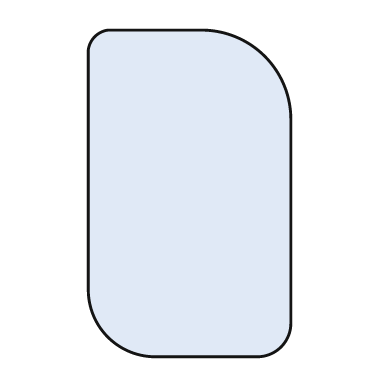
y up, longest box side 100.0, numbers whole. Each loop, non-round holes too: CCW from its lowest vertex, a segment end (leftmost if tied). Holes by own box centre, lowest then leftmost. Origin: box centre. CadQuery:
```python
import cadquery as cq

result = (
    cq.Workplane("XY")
    .moveTo(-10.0, -50.0)
    .lineTo(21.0, -50.0)
    .threePointArc((28.0, -47.0), (31.0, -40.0))
    .lineTo(31.0, 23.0)
    .threePointArc((23.0, 42.0), (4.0, 50.0))
    .lineTo(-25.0, 50.0)
    .threePointArc((-29.0, 48.0), (-31.0, 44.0))
    .lineTo(-31.0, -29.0)
    .threePointArc((-25.0, -44.0), (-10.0, -50.0))
    .close()
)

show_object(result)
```